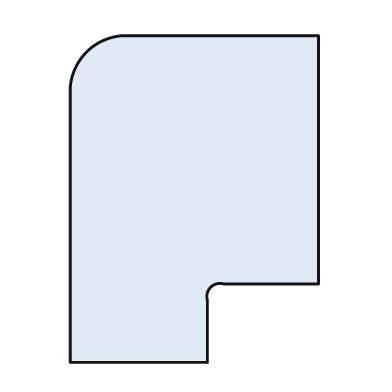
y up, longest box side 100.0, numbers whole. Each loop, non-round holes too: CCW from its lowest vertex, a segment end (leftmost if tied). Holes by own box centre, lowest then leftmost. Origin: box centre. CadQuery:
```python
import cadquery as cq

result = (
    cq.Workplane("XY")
    .moveTo(-38.0, -50.0)
    .lineTo(4.0, -50.0)
    .lineTo(4.0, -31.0)
    .threePointArc((5.0, -27.0), (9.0, -26.0))
    .lineTo(38.0, -26.0)
    .lineTo(38.0, 50.0)
    .lineTo(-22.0, 50.0)
    .threePointArc((-33.0, 45.0), (-38.0, 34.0))
    .close()
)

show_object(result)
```